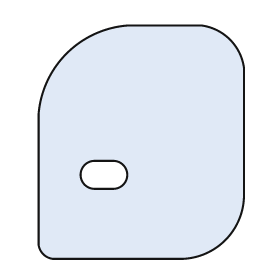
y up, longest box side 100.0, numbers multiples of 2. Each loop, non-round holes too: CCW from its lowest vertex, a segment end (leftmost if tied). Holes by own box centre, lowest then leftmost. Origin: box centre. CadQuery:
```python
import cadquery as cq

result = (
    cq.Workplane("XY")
    .moveTo(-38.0, -50.0)
    .lineTo(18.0, -50.0)
    .threePointArc((36.0, -42.0), (44.0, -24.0))
    .lineTo(44.0, 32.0)
    .threePointArc((38.0, 44.0), (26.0, 50.0))
    .lineTo(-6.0, 50.0)
    .threePointArc((-32.0, 38.0), (-44.0, 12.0))
    .lineTo(-44.0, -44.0)
    .threePointArc((-42.0, -48.0), (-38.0, -50.0))
    .close()
    .moveTo(-20.0, -20.0)
    .lineTo(-12.0, -20.0)
    .threePointArc((-6.0, -14.0), (-12.0, -8.0))
    .lineTo(-20.0, -8.0)
    .threePointArc((-26.0, -14.0), (-20.0, -20.0))
    .close()
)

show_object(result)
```